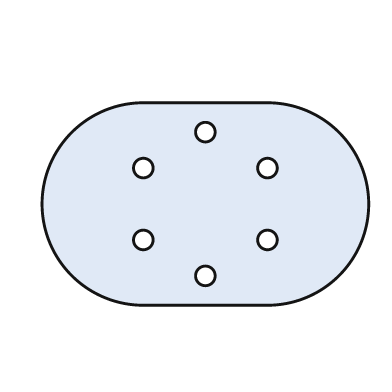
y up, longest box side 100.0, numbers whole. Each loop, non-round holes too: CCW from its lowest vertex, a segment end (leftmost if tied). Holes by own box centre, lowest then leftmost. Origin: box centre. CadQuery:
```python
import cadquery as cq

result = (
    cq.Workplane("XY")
    .moveTo(-19.0, -31.0)
    .lineTo(19.0, -31.0)
    .threePointArc((50.0, 0.0), (19.0, 31.0))
    .lineTo(-19.0, 31.0)
    .threePointArc((-50.0, 0.0), (-19.0, -31.0))
    .close()
    .moveTo(0.0, -22.0)
    .circle(3.0)
    .moveTo(-19.0, -11.0)
    .circle(3.0)
    .moveTo(19.0, -11.0)
    .circle(3.0)
    .moveTo(-19.0, 11.0)
    .circle(3.0)
    .moveTo(19.0, 11.0)
    .circle(3.0)
    .moveTo(0.0, 22.0)
    .circle(3.0)
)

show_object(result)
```